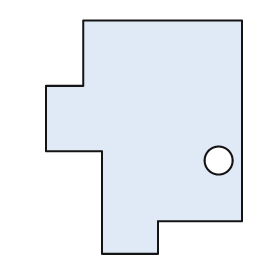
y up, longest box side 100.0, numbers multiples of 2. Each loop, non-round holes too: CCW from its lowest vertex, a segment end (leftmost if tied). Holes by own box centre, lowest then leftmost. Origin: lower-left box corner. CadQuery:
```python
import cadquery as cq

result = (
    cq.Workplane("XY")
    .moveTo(24.0, 0.0)
    .lineTo(48.0, 0.0)
    .lineTo(48.0, 14.0)
    .lineTo(84.0, 14.0)
    .lineTo(84.0, 100.0)
    .lineTo(16.0, 100.0)
    .lineTo(16.0, 72.0)
    .lineTo(0.0, 72.0)
    .lineTo(0.0, 44.0)
    .lineTo(24.0, 44.0)
    .close()
    .moveTo(74.0, 40.0)
    .circle(6.0)
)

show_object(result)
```